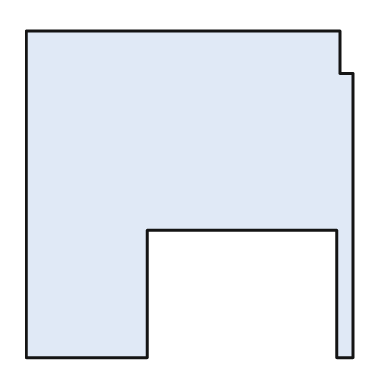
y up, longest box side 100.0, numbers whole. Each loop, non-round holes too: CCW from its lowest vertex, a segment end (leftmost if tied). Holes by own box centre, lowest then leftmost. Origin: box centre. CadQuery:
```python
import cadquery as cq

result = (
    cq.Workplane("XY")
    .moveTo(-50.0, -50.0)
    .lineTo(-13.0, -50.0)
    .lineTo(-13.0, -11.0)
    .lineTo(45.0, -11.0)
    .lineTo(45.0, -50.0)
    .lineTo(50.0, -50.0)
    .lineTo(50.0, 37.0)
    .lineTo(46.0, 37.0)
    .lineTo(46.0, 50.0)
    .lineTo(-50.0, 50.0)
    .close()
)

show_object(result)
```